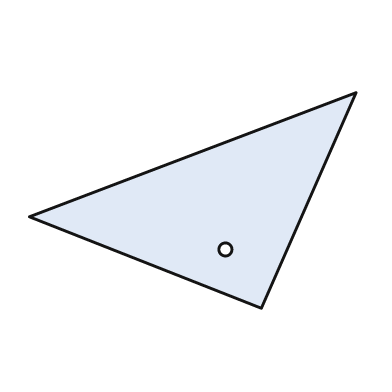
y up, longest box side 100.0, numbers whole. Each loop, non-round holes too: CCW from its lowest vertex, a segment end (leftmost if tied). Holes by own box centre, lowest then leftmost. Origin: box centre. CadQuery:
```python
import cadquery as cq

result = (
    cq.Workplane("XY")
    .moveTo(21.0, -33.0)
    .lineTo(50.0, 33.0)
    .lineTo(-50.0, -5.0)
    .close()
    .moveTo(10.0, -15.0)
    .circle(2.0)
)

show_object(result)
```